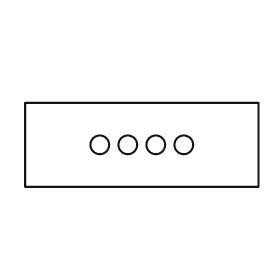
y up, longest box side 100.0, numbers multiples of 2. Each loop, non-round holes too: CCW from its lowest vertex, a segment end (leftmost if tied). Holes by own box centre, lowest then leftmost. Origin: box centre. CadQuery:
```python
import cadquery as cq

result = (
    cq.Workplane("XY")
    .moveTo(-50.0, -18.0)
    .lineTo(50.0, -18.0)
    .lineTo(50.0, 18.0)
    .lineTo(-50.0, 18.0)
    .close()
    .moveTo(-18.0, 0.0)
    .circle(4.0)
    .moveTo(-6.0, 0.0)
    .circle(4.0)
    .moveTo(6.0, 0.0)
    .circle(4.0)
    .moveTo(18.0, 0.0)
    .circle(4.0)
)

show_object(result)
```